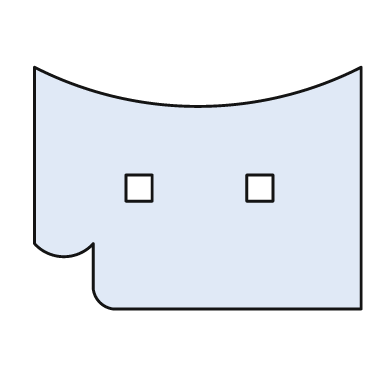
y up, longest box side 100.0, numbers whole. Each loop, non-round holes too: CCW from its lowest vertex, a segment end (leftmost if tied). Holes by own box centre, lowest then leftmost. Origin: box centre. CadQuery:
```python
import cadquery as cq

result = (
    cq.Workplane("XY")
    .moveTo(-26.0, -37.0)
    .lineTo(50.0, -37.0)
    .lineTo(50.0, 37.0)
    .threePointArc((0.0, 25.0), (-50.0, 37.0))
    .lineTo(-50.0, -17.0)
    .threePointArc((-41.0, -21.0), (-32.0, -17.0))
    .lineTo(-32.0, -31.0)
    .threePointArc((-30.0, -35.0), (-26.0, -37.0))
    .close()
    .moveTo(-22.0, -4.0)
    .lineTo(-14.0, -4.0)
    .lineTo(-14.0, 4.0)
    .lineTo(-22.0, 4.0)
    .close()
    .moveTo(15.0, -4.0)
    .lineTo(23.0, -4.0)
    .lineTo(23.0, 4.0)
    .lineTo(15.0, 4.0)
    .close()
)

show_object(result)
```